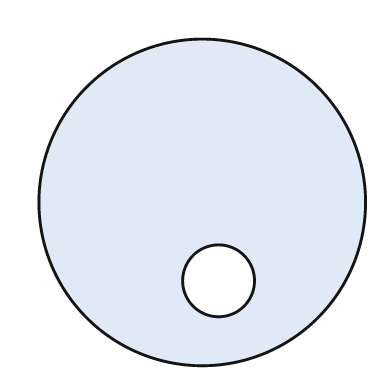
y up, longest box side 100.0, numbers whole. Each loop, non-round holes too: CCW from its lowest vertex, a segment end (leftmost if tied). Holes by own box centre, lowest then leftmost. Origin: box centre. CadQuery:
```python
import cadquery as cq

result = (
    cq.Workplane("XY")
    .moveTo(0.0, 0.0)
    .circle(50.0)
    .moveTo(5.0, -24.0)
    .circle(11.0)
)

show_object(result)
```